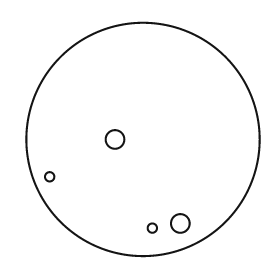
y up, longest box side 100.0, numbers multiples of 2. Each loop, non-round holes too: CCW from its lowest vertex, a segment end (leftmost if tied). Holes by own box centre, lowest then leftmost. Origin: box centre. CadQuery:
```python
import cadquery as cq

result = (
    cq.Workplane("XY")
    .moveTo(0.0, 0.0)
    .circle(50.0)
    .moveTo(4.0, -38.0)
    .circle(2.0)
    .moveTo(16.0, -36.0)
    .circle(4.0)
    .moveTo(-40.0, -16.0)
    .circle(2.0)
    .moveTo(-12.0, 0.0)
    .circle(4.0)
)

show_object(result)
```